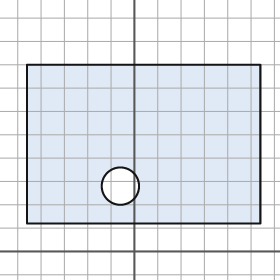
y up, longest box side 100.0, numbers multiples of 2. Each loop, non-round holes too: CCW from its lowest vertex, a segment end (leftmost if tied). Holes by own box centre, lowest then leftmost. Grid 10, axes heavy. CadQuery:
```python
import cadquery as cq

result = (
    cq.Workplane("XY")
    .moveTo(-46.0, 12.0)
    .lineTo(54.0, 12.0)
    .lineTo(54.0, 80.0)
    .lineTo(-46.0, 80.0)
    .close()
    .moveTo(-6.0, 28.0)
    .circle(8.0)
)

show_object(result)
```